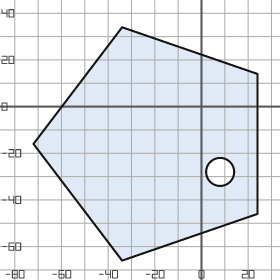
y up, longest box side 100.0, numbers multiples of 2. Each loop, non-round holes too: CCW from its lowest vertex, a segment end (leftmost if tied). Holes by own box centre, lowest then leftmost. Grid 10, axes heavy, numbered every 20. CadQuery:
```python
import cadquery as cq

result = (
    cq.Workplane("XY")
    .moveTo(-34.0, -66.0)
    .lineTo(24.0, -46.0)
    .lineTo(24.0, 14.0)
    .lineTo(-34.0, 34.0)
    .lineTo(-72.0, -16.0)
    .close()
    .moveTo(8.0, -28.0)
    .circle(6.0)
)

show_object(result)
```